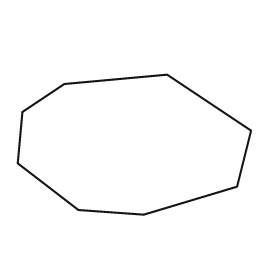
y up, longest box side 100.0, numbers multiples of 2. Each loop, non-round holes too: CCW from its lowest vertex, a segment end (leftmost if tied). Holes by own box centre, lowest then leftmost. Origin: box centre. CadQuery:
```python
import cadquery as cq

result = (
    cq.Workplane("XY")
    .moveTo(4.0, -30.0)
    .lineTo(44.0, -18.0)
    .lineTo(50.0, 6.0)
    .lineTo(14.0, 30.0)
    .lineTo(-30.0, 26.0)
    .lineTo(-48.0, 14.0)
    .lineTo(-50.0, -8.0)
    .lineTo(-24.0, -28.0)
    .close()
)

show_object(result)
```